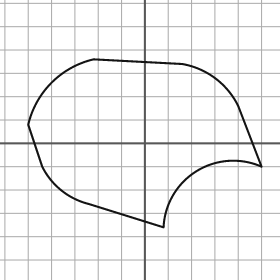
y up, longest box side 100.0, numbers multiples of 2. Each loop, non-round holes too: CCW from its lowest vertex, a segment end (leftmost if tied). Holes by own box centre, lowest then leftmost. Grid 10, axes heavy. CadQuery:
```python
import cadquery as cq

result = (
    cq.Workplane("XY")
    .moveTo(8.0, -36.0)
    .threePointArc((22.0, -12.0), (50.0, -10.0))
    .lineTo(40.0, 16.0)
    .threePointArc((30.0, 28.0), (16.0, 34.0))
    .lineTo(-22.0, 36.0)
    .threePointArc((-40.0, 26.0), (-50.0, 8.0))
    .lineTo(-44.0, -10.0)
    .threePointArc((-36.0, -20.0), (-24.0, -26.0))
    .close()
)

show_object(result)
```